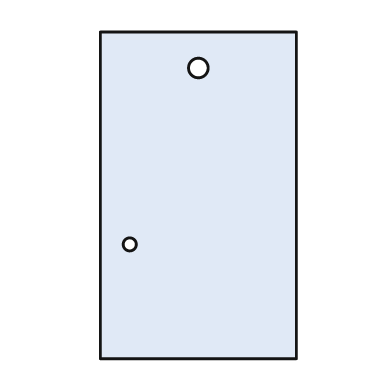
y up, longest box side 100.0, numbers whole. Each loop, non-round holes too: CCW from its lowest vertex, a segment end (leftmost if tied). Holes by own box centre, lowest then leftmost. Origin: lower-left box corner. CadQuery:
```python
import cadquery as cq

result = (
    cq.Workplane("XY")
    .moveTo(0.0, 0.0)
    .lineTo(60.0, 0.0)
    .lineTo(60.0, 100.0)
    .lineTo(0.0, 100.0)
    .close()
    .moveTo(9.0, 35.0)
    .circle(2.0)
    .moveTo(30.0, 89.0)
    .circle(3.0)
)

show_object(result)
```